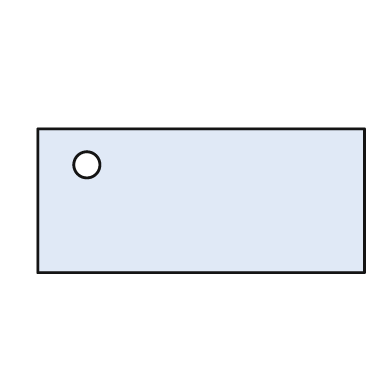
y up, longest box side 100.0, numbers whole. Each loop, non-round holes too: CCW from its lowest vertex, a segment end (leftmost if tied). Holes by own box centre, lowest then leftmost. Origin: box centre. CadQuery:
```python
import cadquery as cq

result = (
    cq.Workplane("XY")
    .moveTo(-50.0, -22.0)
    .lineTo(50.0, -22.0)
    .lineTo(50.0, 22.0)
    .lineTo(-50.0, 22.0)
    .close()
    .moveTo(-35.0, 11.0)
    .circle(4.0)
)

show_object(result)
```